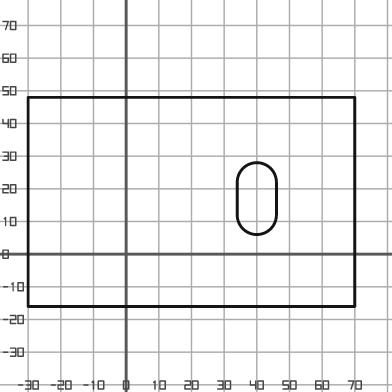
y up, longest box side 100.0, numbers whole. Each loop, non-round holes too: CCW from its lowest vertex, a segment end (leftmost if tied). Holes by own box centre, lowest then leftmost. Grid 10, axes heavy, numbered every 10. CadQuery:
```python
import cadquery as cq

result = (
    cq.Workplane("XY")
    .moveTo(-30.0, -16.0)
    .lineTo(70.0, -16.0)
    .lineTo(70.0, 48.0)
    .lineTo(-30.0, 48.0)
    .close()
    .moveTo(34.0, 12.0)
    .threePointArc((40.0, 6.0), (46.0, 12.0))
    .lineTo(46.0, 22.0)
    .threePointArc((40.0, 28.0), (34.0, 22.0))
    .close()
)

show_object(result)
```